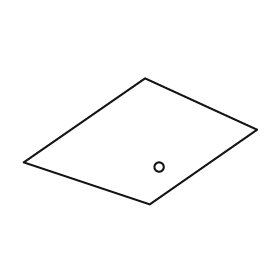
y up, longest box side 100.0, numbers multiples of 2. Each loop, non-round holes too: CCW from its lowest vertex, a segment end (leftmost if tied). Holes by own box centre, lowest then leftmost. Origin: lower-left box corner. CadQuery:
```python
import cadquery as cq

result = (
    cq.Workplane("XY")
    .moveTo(54.0, 0.0)
    .lineTo(100.0, 32.0)
    .lineTo(52.0, 54.0)
    .lineTo(0.0, 18.0)
    .close()
    .moveTo(58.0, 16.0)
    .circle(2.0)
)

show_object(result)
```